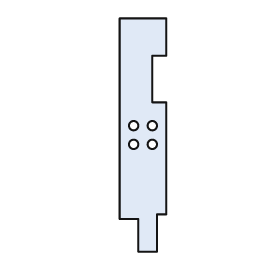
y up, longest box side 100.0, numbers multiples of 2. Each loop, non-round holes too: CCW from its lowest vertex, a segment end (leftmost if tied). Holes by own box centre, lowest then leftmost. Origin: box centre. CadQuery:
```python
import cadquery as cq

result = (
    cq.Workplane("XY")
    .moveTo(-2.0, -50.0)
    .lineTo(6.0, -50.0)
    .lineTo(6.0, -34.0)
    .lineTo(10.0, -34.0)
    .lineTo(10.0, 14.0)
    .lineTo(4.0, 14.0)
    .lineTo(4.0, 34.0)
    .lineTo(10.0, 34.0)
    .lineTo(10.0, 50.0)
    .lineTo(-10.0, 50.0)
    .lineTo(-10.0, -36.0)
    .lineTo(-2.0, -36.0)
    .close()
    .moveTo(-4.0, -4.0)
    .circle(2.0)
    .moveTo(4.0, -4.0)
    .circle(2.0)
    .moveTo(-4.0, 4.0)
    .circle(2.0)
    .moveTo(4.0, 4.0)
    .circle(2.0)
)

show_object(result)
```